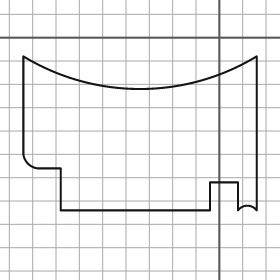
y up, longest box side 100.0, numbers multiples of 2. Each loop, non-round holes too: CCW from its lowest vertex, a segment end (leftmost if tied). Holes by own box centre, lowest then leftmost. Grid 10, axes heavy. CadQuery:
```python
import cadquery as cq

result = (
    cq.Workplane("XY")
    .moveTo(-68.0, -74.0)
    .lineTo(-4.0, -74.0)
    .lineTo(-4.0, -62.0)
    .lineTo(8.0, -62.0)
    .lineTo(8.0, -74.0)
    .threePointArc((12.0, -72.0), (16.0, -74.0))
    .lineTo(16.0, -8.0)
    .threePointArc((-34.0, -22.0), (-84.0, -8.0))
    .lineTo(-84.0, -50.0)
    .threePointArc((-82.0, -54.0), (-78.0, -56.0))
    .lineTo(-68.0, -56.0)
    .close()
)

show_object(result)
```